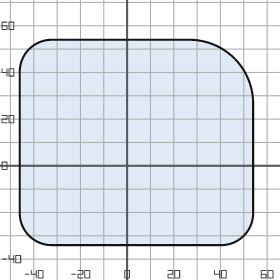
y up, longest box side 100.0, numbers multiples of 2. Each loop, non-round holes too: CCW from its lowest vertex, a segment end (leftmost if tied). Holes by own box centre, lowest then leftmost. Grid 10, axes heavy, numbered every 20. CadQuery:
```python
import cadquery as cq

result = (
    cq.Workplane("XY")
    .moveTo(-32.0, -34.0)
    .lineTo(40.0, -34.0)
    .threePointArc((50.0, -30.0), (54.0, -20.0))
    .lineTo(54.0, 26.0)
    .threePointArc((46.0, 46.0), (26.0, 54.0))
    .lineTo(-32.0, 54.0)
    .threePointArc((-42.0, 50.0), (-46.0, 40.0))
    .lineTo(-46.0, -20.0)
    .threePointArc((-42.0, -30.0), (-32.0, -34.0))
    .close()
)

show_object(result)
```